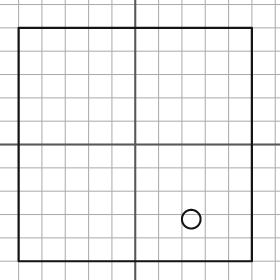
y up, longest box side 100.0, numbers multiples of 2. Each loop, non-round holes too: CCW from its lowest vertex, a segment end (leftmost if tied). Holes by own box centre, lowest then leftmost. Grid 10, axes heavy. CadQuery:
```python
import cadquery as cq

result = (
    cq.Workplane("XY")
    .moveTo(-50.0, -50.0)
    .lineTo(50.0, -50.0)
    .lineTo(50.0, 50.0)
    .lineTo(-50.0, 50.0)
    .close()
    .moveTo(24.0, -32.0)
    .circle(4.0)
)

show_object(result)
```